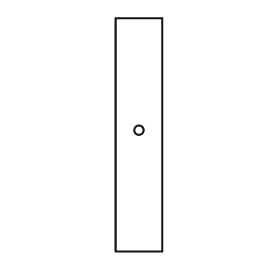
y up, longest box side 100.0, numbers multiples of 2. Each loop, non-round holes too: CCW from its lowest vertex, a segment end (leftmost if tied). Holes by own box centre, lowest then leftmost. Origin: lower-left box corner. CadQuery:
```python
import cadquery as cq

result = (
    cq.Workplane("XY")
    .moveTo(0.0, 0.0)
    .lineTo(20.0, 0.0)
    .lineTo(20.0, 100.0)
    .lineTo(0.0, 100.0)
    .close()
    .moveTo(10.0, 52.0)
    .circle(2.0)
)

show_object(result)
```